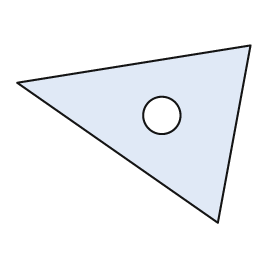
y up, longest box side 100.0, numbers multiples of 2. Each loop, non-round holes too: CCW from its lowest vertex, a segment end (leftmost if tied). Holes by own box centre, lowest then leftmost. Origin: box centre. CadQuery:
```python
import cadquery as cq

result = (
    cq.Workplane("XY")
    .moveTo(36.0, -38.0)
    .lineTo(50.0, 38.0)
    .lineTo(-50.0, 22.0)
    .close()
    .moveTo(12.0, 8.0)
    .circle(8.0)
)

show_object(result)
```